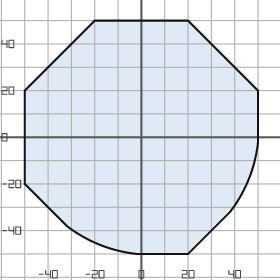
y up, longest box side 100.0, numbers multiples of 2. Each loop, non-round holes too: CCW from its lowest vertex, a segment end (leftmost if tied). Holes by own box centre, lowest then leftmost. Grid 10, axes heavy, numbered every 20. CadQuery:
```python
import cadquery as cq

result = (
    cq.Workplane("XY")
    .moveTo(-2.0, -50.0)
    .lineTo(20.0, -50.0)
    .lineTo(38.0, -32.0)
    .threePointArc((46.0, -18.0), (50.0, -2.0))
    .lineTo(50.0, 20.0)
    .lineTo(20.0, 50.0)
    .lineTo(-20.0, 50.0)
    .lineTo(-50.0, 20.0)
    .lineTo(-50.0, -20.0)
    .lineTo(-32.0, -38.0)
    .threePointArc((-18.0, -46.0), (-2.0, -50.0))
    .close()
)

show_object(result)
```